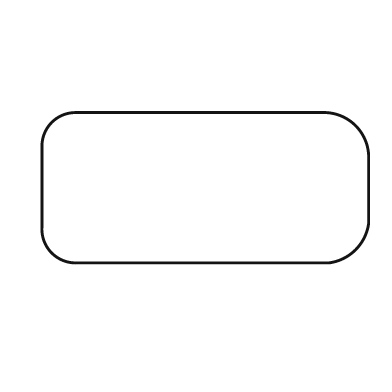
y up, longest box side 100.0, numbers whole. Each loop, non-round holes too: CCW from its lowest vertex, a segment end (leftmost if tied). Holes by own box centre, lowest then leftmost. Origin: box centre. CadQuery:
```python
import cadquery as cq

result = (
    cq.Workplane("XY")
    .moveTo(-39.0, -23.0)
    .lineTo(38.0, -23.0)
    .threePointArc((46.0, -19.0), (50.0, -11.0))
    .lineTo(50.0, 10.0)
    .threePointArc((46.0, 19.0), (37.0, 23.0))
    .lineTo(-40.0, 23.0)
    .threePointArc((-47.0, 20.0), (-50.0, 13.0))
    .lineTo(-50.0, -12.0)
    .threePointArc((-47.0, -20.0), (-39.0, -23.0))
    .close()
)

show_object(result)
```